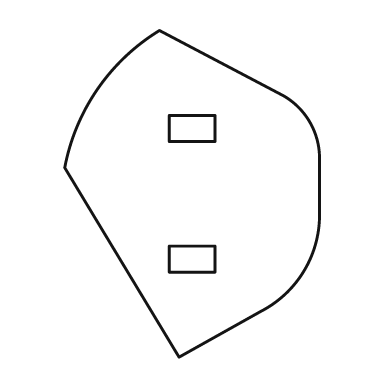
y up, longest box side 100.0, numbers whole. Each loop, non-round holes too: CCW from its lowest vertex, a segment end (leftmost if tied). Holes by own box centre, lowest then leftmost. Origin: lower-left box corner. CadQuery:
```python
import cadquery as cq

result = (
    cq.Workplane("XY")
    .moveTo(35.0, 0.0)
    .lineTo(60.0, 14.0)
    .threePointArc((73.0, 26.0), (78.0, 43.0))
    .lineTo(78.0, 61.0)
    .threePointArc((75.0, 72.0), (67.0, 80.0))
    .lineTo(29.0, 100.0)
    .threePointArc((10.0, 82.0), (0.0, 58.0))
    .close()
    .moveTo(32.0, 26.0)
    .lineTo(46.0, 26.0)
    .lineTo(46.0, 34.0)
    .lineTo(32.0, 34.0)
    .close()
    .moveTo(32.0, 66.0)
    .lineTo(46.0, 66.0)
    .lineTo(46.0, 74.0)
    .lineTo(32.0, 74.0)
    .close()
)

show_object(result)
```